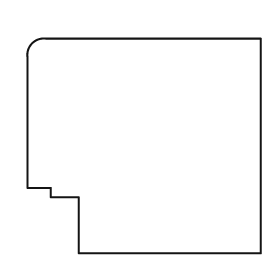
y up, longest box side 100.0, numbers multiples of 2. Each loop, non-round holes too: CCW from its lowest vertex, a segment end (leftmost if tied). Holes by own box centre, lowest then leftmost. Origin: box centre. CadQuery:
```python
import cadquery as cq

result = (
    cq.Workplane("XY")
    .moveTo(-28.0, -46.0)
    .lineTo(50.0, -46.0)
    .lineTo(50.0, 46.0)
    .lineTo(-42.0, 46.0)
    .threePointArc((-48.0, 44.0), (-50.0, 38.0))
    .lineTo(-50.0, -18.0)
    .lineTo(-40.0, -18.0)
    .lineTo(-40.0, -22.0)
    .lineTo(-28.0, -22.0)
    .close()
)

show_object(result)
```